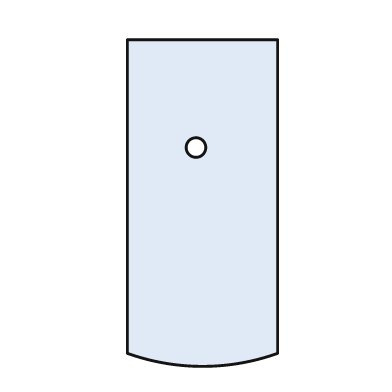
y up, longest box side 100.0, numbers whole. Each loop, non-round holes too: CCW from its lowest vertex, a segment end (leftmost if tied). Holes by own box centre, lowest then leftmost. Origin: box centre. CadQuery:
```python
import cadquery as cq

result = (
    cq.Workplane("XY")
    .moveTo(-23.0, -46.0)
    .threePointArc((0.0, -50.0), (23.0, -46.0))
    .lineTo(23.0, 50.0)
    .lineTo(-23.0, 50.0)
    .close()
    .moveTo(-2.0, 17.0)
    .circle(3.0)
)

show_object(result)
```